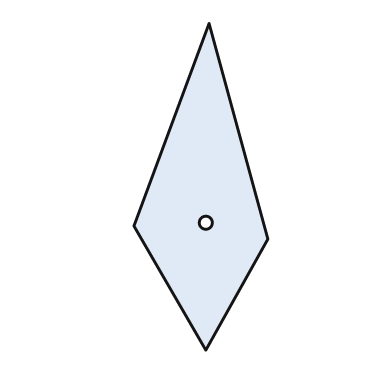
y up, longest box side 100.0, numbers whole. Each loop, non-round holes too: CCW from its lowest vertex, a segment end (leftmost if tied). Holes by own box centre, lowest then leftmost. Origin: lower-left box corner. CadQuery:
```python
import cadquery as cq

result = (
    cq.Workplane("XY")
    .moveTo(22.0, 0.0)
    .lineTo(41.0, 34.0)
    .lineTo(23.0, 100.0)
    .lineTo(0.0, 38.0)
    .close()
    .moveTo(22.0, 39.0)
    .circle(2.0)
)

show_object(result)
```